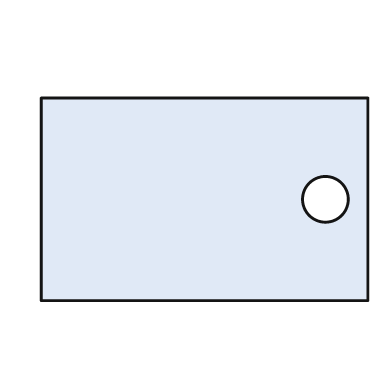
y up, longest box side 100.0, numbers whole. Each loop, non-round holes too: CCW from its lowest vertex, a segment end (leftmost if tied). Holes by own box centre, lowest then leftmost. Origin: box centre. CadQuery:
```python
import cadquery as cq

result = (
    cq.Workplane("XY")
    .moveTo(-50.0, -31.0)
    .lineTo(50.0, -31.0)
    .lineTo(50.0, 31.0)
    .lineTo(-50.0, 31.0)
    .close()
    .moveTo(37.0, 0.0)
    .circle(7.0)
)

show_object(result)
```